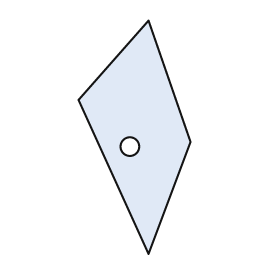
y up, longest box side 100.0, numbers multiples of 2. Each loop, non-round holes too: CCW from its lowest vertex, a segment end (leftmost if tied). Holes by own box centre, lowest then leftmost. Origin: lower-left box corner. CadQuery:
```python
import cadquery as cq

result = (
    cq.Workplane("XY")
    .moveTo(30.0, 0.0)
    .lineTo(48.0, 48.0)
    .lineTo(30.0, 100.0)
    .lineTo(0.0, 66.0)
    .close()
    .moveTo(22.0, 46.0)
    .circle(4.0)
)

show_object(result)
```